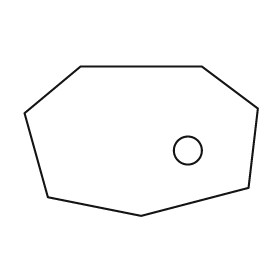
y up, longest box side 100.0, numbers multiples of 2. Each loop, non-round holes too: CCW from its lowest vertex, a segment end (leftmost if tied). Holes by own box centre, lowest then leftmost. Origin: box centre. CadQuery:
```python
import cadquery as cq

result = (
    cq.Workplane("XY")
    .moveTo(0.0, -32.0)
    .lineTo(46.0, -20.0)
    .lineTo(50.0, 14.0)
    .lineTo(26.0, 32.0)
    .lineTo(-26.0, 32.0)
    .lineTo(-50.0, 12.0)
    .lineTo(-40.0, -24.0)
    .close()
    .moveTo(20.0, -4.0)
    .circle(6.0)
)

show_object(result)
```